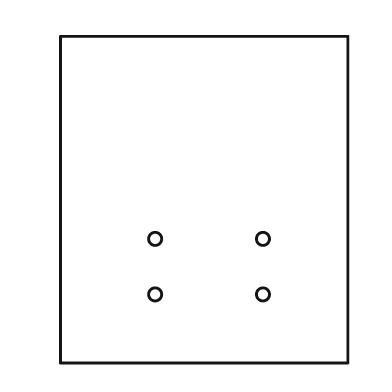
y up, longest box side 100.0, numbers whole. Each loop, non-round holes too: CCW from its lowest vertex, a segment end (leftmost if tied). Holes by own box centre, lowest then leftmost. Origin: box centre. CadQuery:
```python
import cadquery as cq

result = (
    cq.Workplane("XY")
    .moveTo(-44.0, -50.0)
    .lineTo(44.0, -50.0)
    .lineTo(44.0, 50.0)
    .lineTo(-44.0, 50.0)
    .close()
    .moveTo(-15.0, -29.0)
    .circle(2.0)
    .moveTo(18.0, -29.0)
    .circle(2.0)
    .moveTo(-15.0, -12.0)
    .circle(2.0)
    .moveTo(18.0, -12.0)
    .circle(2.0)
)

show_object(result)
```